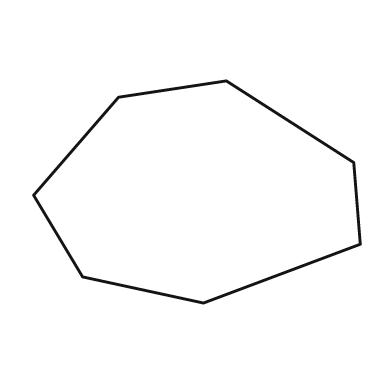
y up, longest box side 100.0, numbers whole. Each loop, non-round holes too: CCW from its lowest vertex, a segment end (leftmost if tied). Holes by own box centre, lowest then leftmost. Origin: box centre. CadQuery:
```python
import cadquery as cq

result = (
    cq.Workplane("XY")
    .moveTo(2.0, -34.0)
    .lineTo(50.0, -16.0)
    .lineTo(48.0, 9.0)
    .lineTo(9.0, 34.0)
    .lineTo(-24.0, 29.0)
    .lineTo(-50.0, -1.0)
    .lineTo(-35.0, -26.0)
    .close()
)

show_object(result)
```